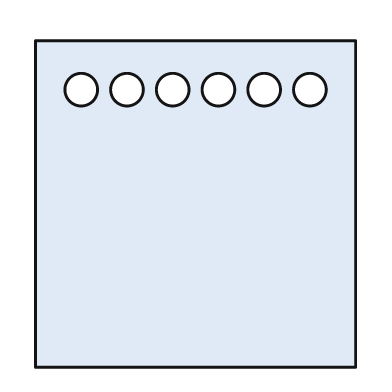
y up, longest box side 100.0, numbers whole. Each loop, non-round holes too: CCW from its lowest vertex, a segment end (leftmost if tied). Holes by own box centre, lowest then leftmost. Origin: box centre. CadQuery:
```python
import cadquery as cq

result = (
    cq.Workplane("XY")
    .moveTo(-49.0, -50.0)
    .lineTo(49.0, -50.0)
    .lineTo(49.0, 50.0)
    .lineTo(-49.0, 50.0)
    .close()
    .moveTo(-35.0, 35.0)
    .circle(5.0)
    .moveTo(-21.0, 35.0)
    .circle(5.0)
    .moveTo(-7.0, 35.0)
    .circle(5.0)
    .moveTo(7.0, 35.0)
    .circle(5.0)
    .moveTo(21.0, 35.0)
    .circle(5.0)
    .moveTo(35.0, 35.0)
    .circle(5.0)
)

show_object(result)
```